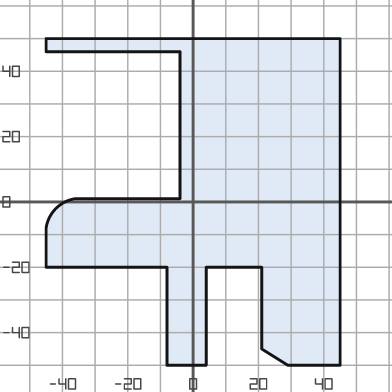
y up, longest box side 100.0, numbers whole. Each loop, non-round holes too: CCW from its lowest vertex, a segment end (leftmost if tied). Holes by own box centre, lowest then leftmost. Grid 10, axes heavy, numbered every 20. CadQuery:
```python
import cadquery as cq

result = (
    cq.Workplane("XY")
    .moveTo(-8.0, -50.0)
    .lineTo(4.0, -50.0)
    .lineTo(4.0, -20.0)
    .lineTo(21.0, -20.0)
    .lineTo(21.0, -45.0)
    .lineTo(29.0, -50.0)
    .lineTo(45.0, -50.0)
    .lineTo(45.0, 50.0)
    .lineTo(-45.0, 50.0)
    .lineTo(-45.0, 46.0)
    .lineTo(-4.0, 46.0)
    .lineTo(-4.0, 1.0)
    .lineTo(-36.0, 1.0)
    .threePointArc((-42.0, -2.0), (-45.0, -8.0))
    .lineTo(-45.0, -20.0)
    .lineTo(-8.0, -20.0)
    .close()
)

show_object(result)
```